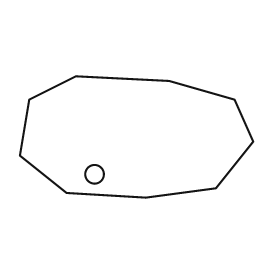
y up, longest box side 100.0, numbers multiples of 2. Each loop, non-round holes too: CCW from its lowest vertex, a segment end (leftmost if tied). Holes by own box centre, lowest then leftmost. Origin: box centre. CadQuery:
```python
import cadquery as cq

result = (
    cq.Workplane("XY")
    .moveTo(4.0, -26.0)
    .lineTo(34.0, -22.0)
    .lineTo(50.0, -2.0)
    .lineTo(42.0, 16.0)
    .lineTo(14.0, 24.0)
    .lineTo(-26.0, 26.0)
    .lineTo(-46.0, 16.0)
    .lineTo(-50.0, -8.0)
    .lineTo(-30.0, -24.0)
    .close()
    .moveTo(-18.0, -16.0)
    .circle(4.0)
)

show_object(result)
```